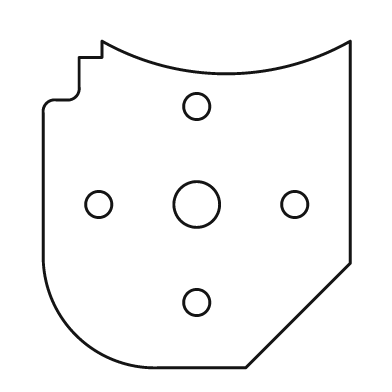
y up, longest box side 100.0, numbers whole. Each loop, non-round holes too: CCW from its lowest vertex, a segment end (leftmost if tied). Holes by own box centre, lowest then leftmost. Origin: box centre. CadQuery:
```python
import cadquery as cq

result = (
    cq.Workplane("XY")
    .moveTo(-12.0, -50.0)
    .lineTo(15.0, -50.0)
    .lineTo(47.0, -18.0)
    .lineTo(47.0, 50.0)
    .threePointArc((9.0, 40.0), (-29.0, 50.0))
    .lineTo(-29.0, 45.0)
    .lineTo(-36.0, 45.0)
    .lineTo(-36.0, 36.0)
    .threePointArc((-37.0, 33.0), (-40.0, 32.0))
    .lineTo(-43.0, 32.0)
    .threePointArc((-46.0, 31.0), (-47.0, 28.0))
    .lineTo(-47.0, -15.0)
    .threePointArc((-37.0, -40.0), (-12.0, -50.0))
    .close()
    .moveTo(0.0, -30.0)
    .circle(4.0)
    .moveTo(-30.0, 0.0)
    .circle(4.0)
    .moveTo(0.0, 0.0)
    .circle(7.0)
    .moveTo(30.0, 0.0)
    .circle(4.0)
    .moveTo(0.0, 30.0)
    .circle(4.0)
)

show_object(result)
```